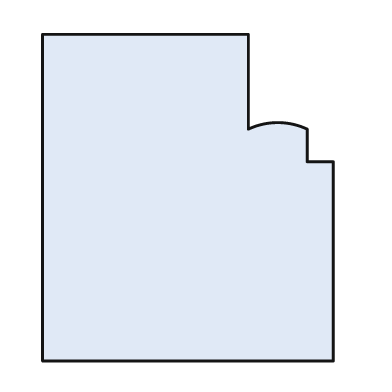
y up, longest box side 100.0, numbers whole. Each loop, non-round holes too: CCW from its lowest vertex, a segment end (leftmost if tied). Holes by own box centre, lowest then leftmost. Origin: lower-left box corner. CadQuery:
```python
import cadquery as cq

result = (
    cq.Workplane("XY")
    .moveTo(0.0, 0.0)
    .lineTo(89.0, 0.0)
    .lineTo(89.0, 61.0)
    .lineTo(81.0, 61.0)
    .lineTo(81.0, 71.0)
    .threePointArc((72.0, 73.0), (63.0, 71.0))
    .lineTo(63.0, 100.0)
    .lineTo(0.0, 100.0)
    .close()
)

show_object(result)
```